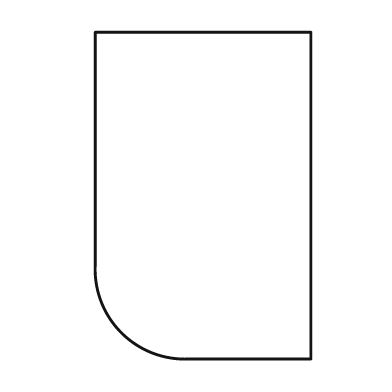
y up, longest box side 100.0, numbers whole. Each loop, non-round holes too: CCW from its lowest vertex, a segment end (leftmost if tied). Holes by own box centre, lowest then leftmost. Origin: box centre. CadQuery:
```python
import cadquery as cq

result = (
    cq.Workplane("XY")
    .moveTo(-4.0, -50.0)
    .lineTo(33.0, -50.0)
    .lineTo(33.0, 50.0)
    .lineTo(-33.0, 50.0)
    .lineTo(-33.0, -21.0)
    .threePointArc((-25.0, -42.0), (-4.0, -50.0))
    .close()
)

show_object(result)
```